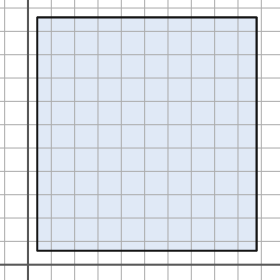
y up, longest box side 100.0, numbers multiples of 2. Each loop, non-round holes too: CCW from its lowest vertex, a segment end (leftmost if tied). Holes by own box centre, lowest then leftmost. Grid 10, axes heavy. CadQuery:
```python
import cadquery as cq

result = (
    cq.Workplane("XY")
    .moveTo(4.0, 6.0)
    .lineTo(98.0, 6.0)
    .lineTo(98.0, 106.0)
    .lineTo(4.0, 106.0)
    .close()
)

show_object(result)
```